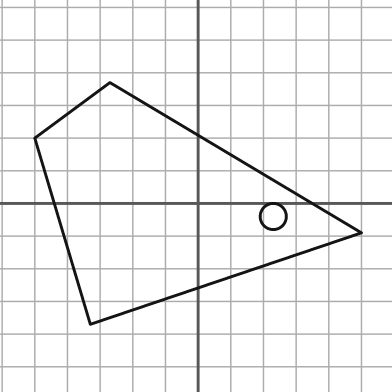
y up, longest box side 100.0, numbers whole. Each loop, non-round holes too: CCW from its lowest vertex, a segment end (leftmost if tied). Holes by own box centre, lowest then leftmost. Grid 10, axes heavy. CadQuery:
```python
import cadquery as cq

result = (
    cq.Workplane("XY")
    .moveTo(-33.0, -37.0)
    .lineTo(50.0, -9.0)
    .lineTo(-27.0, 37.0)
    .lineTo(-50.0, 20.0)
    .close()
    .moveTo(23.0, -4.0)
    .circle(4.0)
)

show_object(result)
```